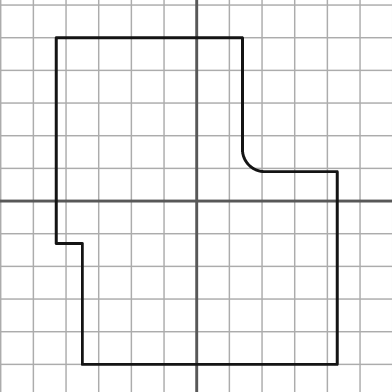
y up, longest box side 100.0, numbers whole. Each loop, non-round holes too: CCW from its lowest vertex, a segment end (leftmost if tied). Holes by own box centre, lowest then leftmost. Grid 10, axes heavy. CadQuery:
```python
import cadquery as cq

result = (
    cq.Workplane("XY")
    .moveTo(-35.0, -50.0)
    .lineTo(43.0, -50.0)
    .lineTo(43.0, 9.0)
    .lineTo(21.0, 9.0)
    .threePointArc((16.0, 11.0), (14.0, 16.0))
    .lineTo(14.0, 50.0)
    .lineTo(-43.0, 50.0)
    .lineTo(-43.0, -13.0)
    .lineTo(-35.0, -13.0)
    .close()
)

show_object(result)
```